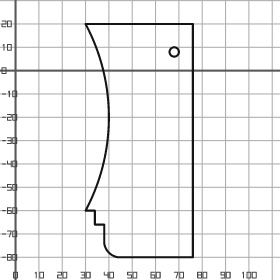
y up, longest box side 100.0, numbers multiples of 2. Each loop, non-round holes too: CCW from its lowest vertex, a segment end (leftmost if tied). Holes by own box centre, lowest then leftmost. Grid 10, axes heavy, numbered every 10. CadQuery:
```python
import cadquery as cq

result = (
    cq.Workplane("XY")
    .moveTo(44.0, -80.0)
    .lineTo(76.0, -80.0)
    .lineTo(76.0, 20.0)
    .lineTo(30.0, 20.0)
    .threePointArc((40.0, -20.0), (30.0, -60.0))
    .lineTo(34.0, -60.0)
    .lineTo(34.0, -66.0)
    .lineTo(38.0, -66.0)
    .lineTo(38.0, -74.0)
    .threePointArc((40.0, -78.0), (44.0, -80.0))
    .close()
    .moveTo(68.0, 8.0)
    .circle(2.0)
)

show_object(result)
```